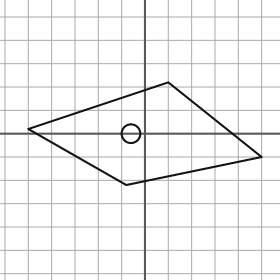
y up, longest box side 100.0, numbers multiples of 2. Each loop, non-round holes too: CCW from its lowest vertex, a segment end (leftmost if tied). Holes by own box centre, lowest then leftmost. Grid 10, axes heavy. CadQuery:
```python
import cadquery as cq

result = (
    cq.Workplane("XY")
    .moveTo(-8.0, -22.0)
    .lineTo(50.0, -10.0)
    .lineTo(10.0, 22.0)
    .lineTo(-50.0, 2.0)
    .close()
    .moveTo(-6.0, 0.0)
    .circle(4.0)
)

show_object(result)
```